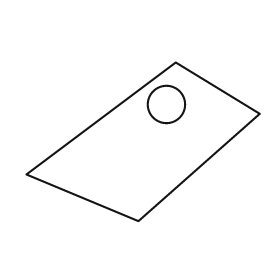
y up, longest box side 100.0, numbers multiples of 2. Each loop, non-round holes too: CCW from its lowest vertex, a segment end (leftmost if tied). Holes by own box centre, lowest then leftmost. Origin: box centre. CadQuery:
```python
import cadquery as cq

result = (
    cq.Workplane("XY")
    .moveTo(-2.0, -34.0)
    .lineTo(50.0, 12.0)
    .lineTo(14.0, 34.0)
    .lineTo(-50.0, -14.0)
    .close()
    .moveTo(10.0, 16.0)
    .circle(8.0)
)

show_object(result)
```